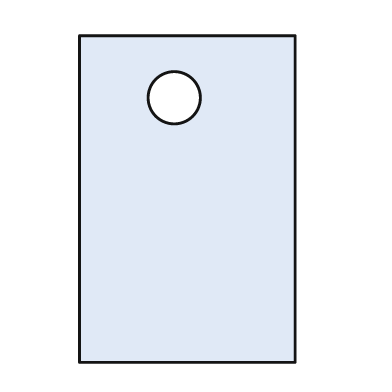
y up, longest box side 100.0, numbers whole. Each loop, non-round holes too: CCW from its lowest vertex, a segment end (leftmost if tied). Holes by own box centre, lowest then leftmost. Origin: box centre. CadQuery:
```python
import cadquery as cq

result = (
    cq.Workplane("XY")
    .moveTo(-33.0, -50.0)
    .lineTo(33.0, -50.0)
    .lineTo(33.0, 50.0)
    .lineTo(-33.0, 50.0)
    .close()
    .moveTo(-4.0, 31.0)
    .circle(8.0)
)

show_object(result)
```